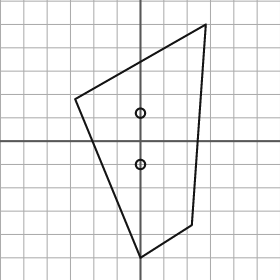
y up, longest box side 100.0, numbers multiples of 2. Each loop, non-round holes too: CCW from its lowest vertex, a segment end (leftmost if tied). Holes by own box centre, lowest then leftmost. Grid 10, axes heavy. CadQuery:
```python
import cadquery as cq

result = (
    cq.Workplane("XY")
    .moveTo(0.0, -50.0)
    .lineTo(22.0, -36.0)
    .lineTo(28.0, 50.0)
    .lineTo(-28.0, 18.0)
    .close()
    .moveTo(0.0, -10.0)
    .circle(2.0)
    .moveTo(0.0, 12.0)
    .circle(2.0)
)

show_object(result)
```